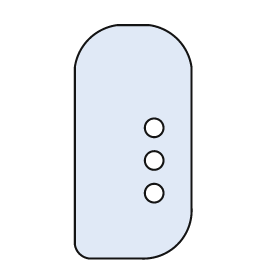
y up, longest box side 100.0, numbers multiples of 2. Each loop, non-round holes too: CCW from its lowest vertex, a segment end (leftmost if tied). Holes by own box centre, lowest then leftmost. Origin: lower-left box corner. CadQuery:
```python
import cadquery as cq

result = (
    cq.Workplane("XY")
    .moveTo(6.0, 0.0)
    .lineTo(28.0, 0.0)
    .threePointArc((44.0, 6.0), (50.0, 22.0))
    .lineTo(50.0, 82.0)
    .threePointArc((44.0, 94.0), (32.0, 100.0))
    .lineTo(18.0, 100.0)
    .threePointArc((6.0, 94.0), (0.0, 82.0))
    .lineTo(0.0, 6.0)
    .threePointArc((2.0, 2.0), (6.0, 0.0))
    .close()
    .moveTo(34.0, 28.0)
    .circle(4.0)
    .moveTo(34.0, 42.0)
    .circle(4.0)
    .moveTo(34.0, 56.0)
    .circle(4.0)
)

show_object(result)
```